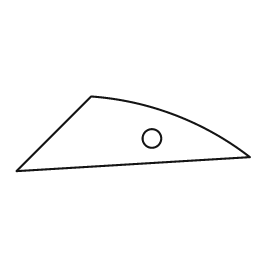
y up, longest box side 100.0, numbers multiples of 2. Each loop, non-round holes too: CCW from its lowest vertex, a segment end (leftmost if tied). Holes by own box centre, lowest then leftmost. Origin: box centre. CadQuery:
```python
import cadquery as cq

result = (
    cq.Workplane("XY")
    .moveTo(-50.0, -16.0)
    .lineTo(50.0, -10.0)
    .threePointArc((18.0, 8.0), (-18.0, 16.0))
    .close()
    .moveTo(8.0, -2.0)
    .circle(4.0)
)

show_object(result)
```